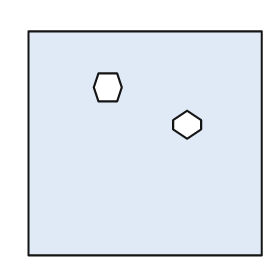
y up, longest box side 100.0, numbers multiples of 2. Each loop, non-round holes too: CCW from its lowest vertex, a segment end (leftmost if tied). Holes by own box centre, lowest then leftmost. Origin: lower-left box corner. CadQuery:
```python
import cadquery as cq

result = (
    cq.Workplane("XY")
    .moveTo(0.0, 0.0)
    .lineTo(100.0, 0.0)
    .lineTo(100.0, 96.0)
    .lineTo(0.0, 96.0)
    .close()
    .moveTo(68.0, 50.0)
    .lineTo(74.0, 54.0)
    .lineTo(74.0, 58.0)
    .lineTo(68.0, 62.0)
    .lineTo(62.0, 58.0)
    .lineTo(62.0, 54.0)
    .close()
    .moveTo(30.0, 66.0)
    .lineTo(38.0, 66.0)
    .lineTo(40.0, 72.0)
    .lineTo(38.0, 78.0)
    .lineTo(30.0, 78.0)
    .lineTo(28.0, 72.0)
    .close()
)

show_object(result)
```